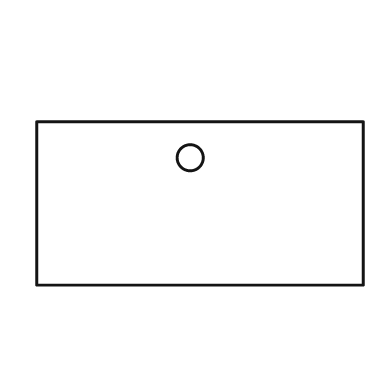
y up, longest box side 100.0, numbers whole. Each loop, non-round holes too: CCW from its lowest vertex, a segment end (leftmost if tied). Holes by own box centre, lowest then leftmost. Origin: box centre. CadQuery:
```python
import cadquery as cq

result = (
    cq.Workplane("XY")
    .moveTo(-50.0, -25.0)
    .lineTo(50.0, -25.0)
    .lineTo(50.0, 25.0)
    .lineTo(-50.0, 25.0)
    .close()
    .moveTo(-3.0, 14.0)
    .circle(4.0)
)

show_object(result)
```